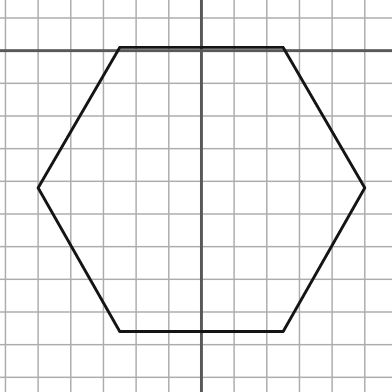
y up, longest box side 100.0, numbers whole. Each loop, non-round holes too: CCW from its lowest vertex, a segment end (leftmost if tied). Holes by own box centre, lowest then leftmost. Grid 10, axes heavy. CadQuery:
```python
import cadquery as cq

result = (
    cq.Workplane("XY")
    .moveTo(-25.0, -86.0)
    .lineTo(25.0, -86.0)
    .lineTo(50.0, -42.0)
    .lineTo(25.0, 1.0)
    .lineTo(-25.0, 1.0)
    .lineTo(-50.0, -42.0)
    .close()
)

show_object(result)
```